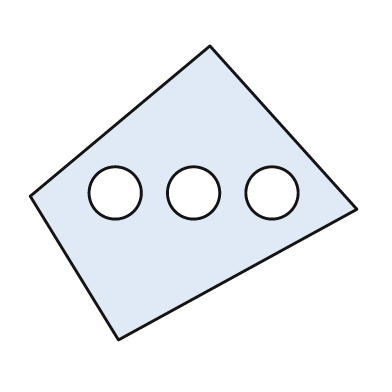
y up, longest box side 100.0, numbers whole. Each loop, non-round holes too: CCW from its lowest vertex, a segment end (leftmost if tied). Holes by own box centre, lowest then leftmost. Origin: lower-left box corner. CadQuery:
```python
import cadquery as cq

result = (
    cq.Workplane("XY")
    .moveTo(27.0, 0.0)
    .lineTo(100.0, 40.0)
    .lineTo(55.0, 90.0)
    .lineTo(0.0, 44.0)
    .close()
    .moveTo(26.0, 45.0)
    .circle(8.0)
    .moveTo(50.0, 45.0)
    .circle(8.0)
    .moveTo(74.0, 45.0)
    .circle(8.0)
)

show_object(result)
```